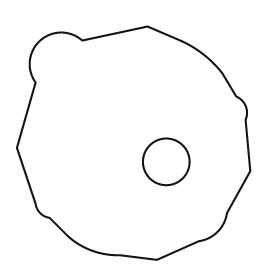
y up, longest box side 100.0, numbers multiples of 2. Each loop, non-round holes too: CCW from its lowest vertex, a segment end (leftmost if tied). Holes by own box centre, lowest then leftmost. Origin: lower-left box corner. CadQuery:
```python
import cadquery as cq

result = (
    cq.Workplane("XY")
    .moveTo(60.0, 0.0)
    .lineTo(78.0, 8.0)
    .threePointArc((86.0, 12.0), (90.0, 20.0))
    .lineTo(100.0, 38.0)
    .lineTo(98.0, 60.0)
    .threePointArc((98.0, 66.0), (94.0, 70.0))
    .lineTo(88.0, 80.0)
    .threePointArc((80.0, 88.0), (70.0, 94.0))
    .lineTo(56.0, 100.0)
    .lineTo(28.0, 94.0)
    .threePointArc((10.0, 94.0), (8.0, 76.0))
    .lineTo(0.0, 48.0)
    .lineTo(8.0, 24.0)
    .threePointArc((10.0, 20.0), (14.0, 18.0))
    .lineTo(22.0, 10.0)
    .threePointArc((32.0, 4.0), (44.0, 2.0))
    .close()
    .moveTo(64.0, 42.0)
    .circle(10.0)
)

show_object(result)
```